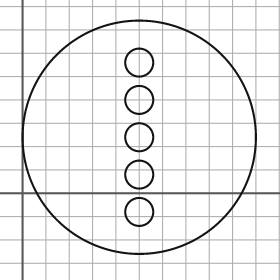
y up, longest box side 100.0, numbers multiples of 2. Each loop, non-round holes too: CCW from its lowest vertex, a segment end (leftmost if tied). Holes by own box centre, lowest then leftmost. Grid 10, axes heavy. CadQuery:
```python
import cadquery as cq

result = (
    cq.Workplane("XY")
    .moveTo(50.0, 24.0)
    .circle(50.0)
    .moveTo(50.0, -8.0)
    .circle(6.0)
    .moveTo(50.0, 8.0)
    .circle(6.0)
    .moveTo(50.0, 24.0)
    .circle(6.0)
    .moveTo(50.0, 40.0)
    .circle(6.0)
    .moveTo(50.0, 56.0)
    .circle(6.0)
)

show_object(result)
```